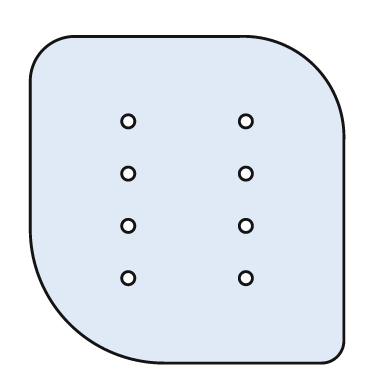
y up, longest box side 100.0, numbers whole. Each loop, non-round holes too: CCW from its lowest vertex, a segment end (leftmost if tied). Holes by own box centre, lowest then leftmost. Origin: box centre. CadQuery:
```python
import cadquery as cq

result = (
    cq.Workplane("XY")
    .moveTo(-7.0, -50.0)
    .lineTo(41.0, -50.0)
    .threePointArc((46.0, -48.0), (48.0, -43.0))
    .lineTo(48.0, 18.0)
    .threePointArc((39.0, 41.0), (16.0, 50.0))
    .lineTo(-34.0, 50.0)
    .threePointArc((-44.0, 46.0), (-48.0, 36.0))
    .lineTo(-48.0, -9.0)
    .threePointArc((-36.0, -38.0), (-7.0, -50.0))
    .close()
    .moveTo(-18.0, -24.0)
    .circle(2.0)
    .moveTo(18.0, -24.0)
    .circle(2.0)
    .moveTo(-18.0, -8.0)
    .circle(2.0)
    .moveTo(18.0, -8.0)
    .circle(2.0)
    .moveTo(-18.0, 8.0)
    .circle(2.0)
    .moveTo(18.0, 8.0)
    .circle(2.0)
    .moveTo(-18.0, 24.0)
    .circle(2.0)
    .moveTo(18.0, 24.0)
    .circle(2.0)
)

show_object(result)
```